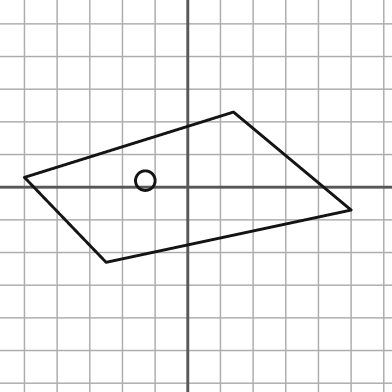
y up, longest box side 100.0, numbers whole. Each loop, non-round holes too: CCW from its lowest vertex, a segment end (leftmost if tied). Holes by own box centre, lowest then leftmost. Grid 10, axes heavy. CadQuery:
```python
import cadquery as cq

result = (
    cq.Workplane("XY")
    .moveTo(-25.0, -23.0)
    .lineTo(50.0, -7.0)
    .lineTo(14.0, 23.0)
    .lineTo(-50.0, 3.0)
    .close()
    .moveTo(-13.0, 2.0)
    .circle(3.0)
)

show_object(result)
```